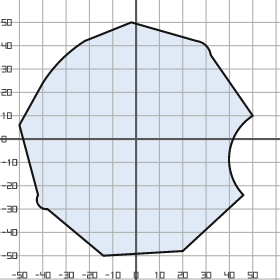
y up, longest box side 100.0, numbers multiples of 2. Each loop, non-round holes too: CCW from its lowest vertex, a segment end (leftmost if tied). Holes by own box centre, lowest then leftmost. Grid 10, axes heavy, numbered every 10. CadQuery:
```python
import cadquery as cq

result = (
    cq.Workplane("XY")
    .moveTo(-14.0, -50.0)
    .lineTo(20.0, -48.0)
    .lineTo(46.0, -24.0)
    .threePointArc((40.0, -6.0), (50.0, 10.0))
    .lineTo(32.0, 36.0)
    .threePointArc((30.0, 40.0), (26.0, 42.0))
    .lineTo(-2.0, 50.0)
    .lineTo(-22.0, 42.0)
    .threePointArc((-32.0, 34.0), (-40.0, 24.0))
    .lineTo(-50.0, 6.0)
    .lineTo(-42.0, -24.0)
    .threePointArc((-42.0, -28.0), (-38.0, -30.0))
    .close()
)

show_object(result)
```